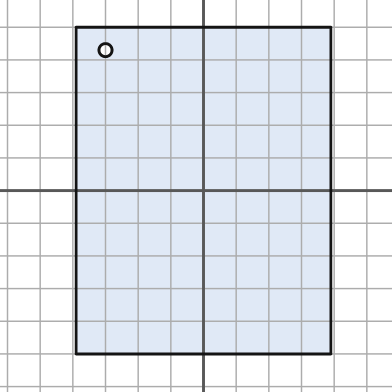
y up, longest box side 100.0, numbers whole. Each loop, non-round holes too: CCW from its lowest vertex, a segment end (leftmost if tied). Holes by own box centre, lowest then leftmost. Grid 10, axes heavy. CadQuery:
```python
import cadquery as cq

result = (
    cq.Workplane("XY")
    .moveTo(-39.0, -50.0)
    .lineTo(39.0, -50.0)
    .lineTo(39.0, 50.0)
    .lineTo(-39.0, 50.0)
    .close()
    .moveTo(-30.0, 43.0)
    .circle(2.0)
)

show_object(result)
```